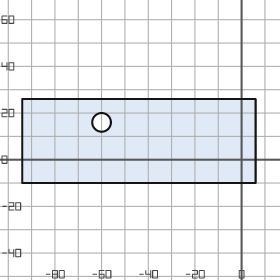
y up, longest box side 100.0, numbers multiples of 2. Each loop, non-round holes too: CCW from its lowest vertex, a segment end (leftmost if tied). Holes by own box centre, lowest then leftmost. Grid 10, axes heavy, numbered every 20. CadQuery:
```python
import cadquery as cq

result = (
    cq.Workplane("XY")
    .moveTo(-94.0, -10.0)
    .lineTo(6.0, -10.0)
    .lineTo(6.0, 26.0)
    .lineTo(-94.0, 26.0)
    .close()
    .moveTo(-60.0, 16.0)
    .circle(4.0)
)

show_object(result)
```